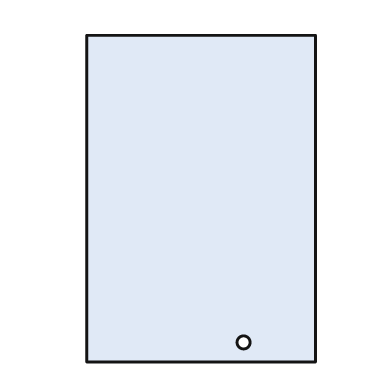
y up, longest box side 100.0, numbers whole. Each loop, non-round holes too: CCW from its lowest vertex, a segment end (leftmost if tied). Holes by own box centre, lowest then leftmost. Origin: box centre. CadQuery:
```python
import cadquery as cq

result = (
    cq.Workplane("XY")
    .moveTo(-35.0, -50.0)
    .lineTo(35.0, -50.0)
    .lineTo(35.0, 50.0)
    .lineTo(-35.0, 50.0)
    .close()
    .moveTo(13.0, -44.0)
    .circle(2.0)
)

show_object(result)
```